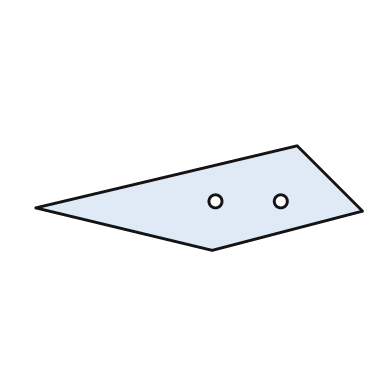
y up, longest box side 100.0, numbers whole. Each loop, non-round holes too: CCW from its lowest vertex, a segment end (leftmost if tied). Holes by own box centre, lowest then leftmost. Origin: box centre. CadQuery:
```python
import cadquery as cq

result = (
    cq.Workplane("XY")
    .moveTo(4.0, -16.0)
    .lineTo(50.0, -4.0)
    .lineTo(30.0, 16.0)
    .lineTo(-50.0, -3.0)
    .close()
    .moveTo(5.0, -1.0)
    .circle(2.0)
    .moveTo(25.0, -1.0)
    .circle(2.0)
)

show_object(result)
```